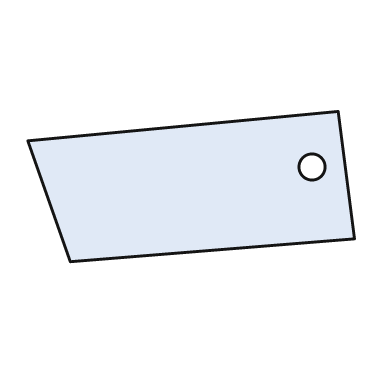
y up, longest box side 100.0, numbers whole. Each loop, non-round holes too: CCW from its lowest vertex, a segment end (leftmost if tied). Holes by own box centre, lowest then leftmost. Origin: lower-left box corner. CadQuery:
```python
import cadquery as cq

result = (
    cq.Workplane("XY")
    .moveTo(13.0, 0.0)
    .lineTo(100.0, 7.0)
    .lineTo(95.0, 46.0)
    .lineTo(0.0, 37.0)
    .close()
    .moveTo(87.0, 29.0)
    .circle(4.0)
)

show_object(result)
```